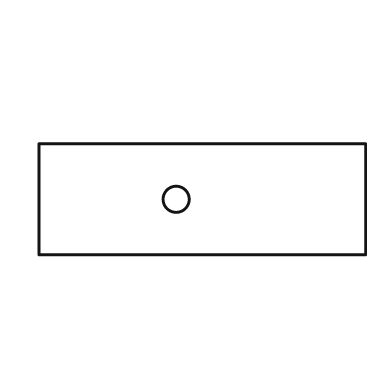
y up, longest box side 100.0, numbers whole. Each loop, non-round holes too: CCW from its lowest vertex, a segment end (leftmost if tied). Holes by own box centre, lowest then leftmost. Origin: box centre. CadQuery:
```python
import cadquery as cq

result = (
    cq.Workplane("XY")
    .moveTo(-50.0, -17.0)
    .lineTo(50.0, -17.0)
    .lineTo(50.0, 17.0)
    .lineTo(-50.0, 17.0)
    .close()
    .moveTo(-8.0, 0.0)
    .circle(4.0)
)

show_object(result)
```